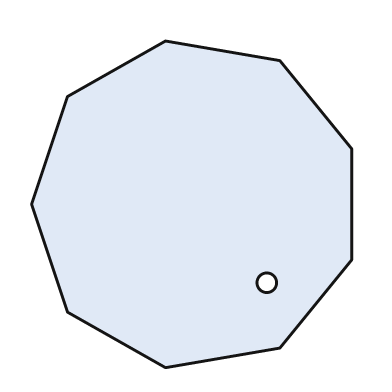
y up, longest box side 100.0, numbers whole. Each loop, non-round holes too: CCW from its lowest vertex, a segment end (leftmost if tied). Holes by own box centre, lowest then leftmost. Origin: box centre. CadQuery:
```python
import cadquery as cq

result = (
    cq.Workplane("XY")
    .moveTo(-8.0, -50.0)
    .lineTo(27.0, -44.0)
    .lineTo(49.0, -17.0)
    .lineTo(49.0, 17.0)
    .lineTo(27.0, 44.0)
    .lineTo(-8.0, 50.0)
    .lineTo(-38.0, 33.0)
    .lineTo(-49.0, 0.0)
    .lineTo(-38.0, -33.0)
    .close()
    .moveTo(23.0, -24.0)
    .circle(3.0)
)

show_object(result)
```